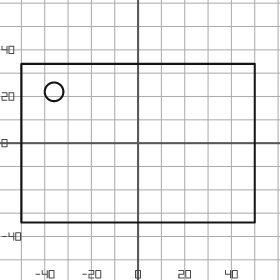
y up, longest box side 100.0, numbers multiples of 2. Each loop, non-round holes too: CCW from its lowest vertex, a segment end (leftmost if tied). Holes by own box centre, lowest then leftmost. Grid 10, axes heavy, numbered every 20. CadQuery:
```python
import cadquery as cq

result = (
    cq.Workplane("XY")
    .moveTo(-50.0, -34.0)
    .lineTo(50.0, -34.0)
    .lineTo(50.0, 34.0)
    .lineTo(-50.0, 34.0)
    .close()
    .moveTo(-36.0, 22.0)
    .circle(4.0)
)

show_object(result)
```